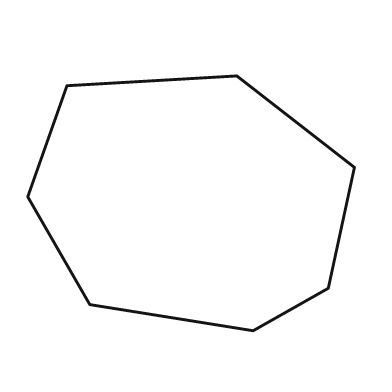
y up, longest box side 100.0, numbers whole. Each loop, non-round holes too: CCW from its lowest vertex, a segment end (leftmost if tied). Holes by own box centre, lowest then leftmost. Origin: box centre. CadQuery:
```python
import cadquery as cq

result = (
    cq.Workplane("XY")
    .moveTo(19.0, -39.0)
    .lineTo(42.0, -26.0)
    .lineTo(50.0, 11.0)
    .lineTo(14.0, 39.0)
    .lineTo(-38.0, 36.0)
    .lineTo(-50.0, 2.0)
    .lineTo(-31.0, -31.0)
    .close()
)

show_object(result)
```